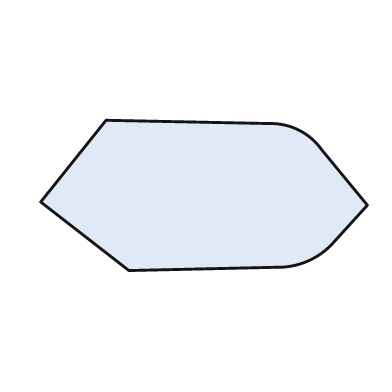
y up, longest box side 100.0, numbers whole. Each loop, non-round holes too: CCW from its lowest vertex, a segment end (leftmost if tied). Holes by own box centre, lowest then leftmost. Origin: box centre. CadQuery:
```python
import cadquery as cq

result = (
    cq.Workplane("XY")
    .moveTo(-23.0, -23.0)
    .lineTo(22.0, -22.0)
    .threePointArc((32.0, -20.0), (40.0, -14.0))
    .lineTo(50.0, -3.0)
    .lineTo(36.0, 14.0)
    .threePointArc((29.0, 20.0), (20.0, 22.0))
    .lineTo(-30.0, 23.0)
    .lineTo(-50.0, -2.0)
    .close()
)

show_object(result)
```